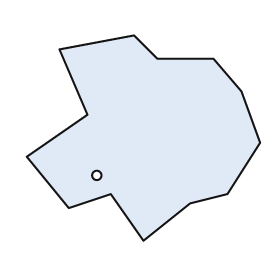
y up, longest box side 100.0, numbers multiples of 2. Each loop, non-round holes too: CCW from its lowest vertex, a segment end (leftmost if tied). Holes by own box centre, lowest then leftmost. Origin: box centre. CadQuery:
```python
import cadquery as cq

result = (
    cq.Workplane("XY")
    .moveTo(0.0, -44.0)
    .lineTo(20.0, -28.0)
    .lineTo(36.0, -24.0)
    .lineTo(50.0, -2.0)
    .lineTo(42.0, 20.0)
    .lineTo(30.0, 34.0)
    .lineTo(6.0, 34.0)
    .lineTo(-4.0, 44.0)
    .lineTo(-36.0, 38.0)
    .lineTo(-24.0, 10.0)
    .lineTo(-50.0, -8.0)
    .lineTo(-32.0, -30.0)
    .lineTo(-14.0, -24.0)
    .close()
    .moveTo(-20.0, -16.0)
    .circle(2.0)
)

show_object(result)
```